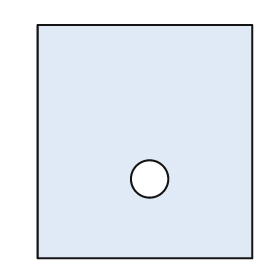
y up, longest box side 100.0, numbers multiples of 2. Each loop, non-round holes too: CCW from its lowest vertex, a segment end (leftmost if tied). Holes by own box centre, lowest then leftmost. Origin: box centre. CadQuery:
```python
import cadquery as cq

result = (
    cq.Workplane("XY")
    .moveTo(-46.0, -50.0)
    .lineTo(46.0, -50.0)
    .lineTo(46.0, 50.0)
    .lineTo(-46.0, 50.0)
    .close()
    .moveTo(2.0, -16.0)
    .circle(8.0)
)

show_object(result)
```